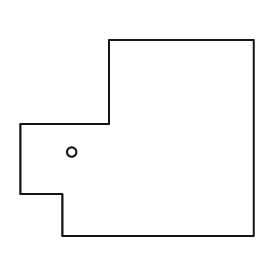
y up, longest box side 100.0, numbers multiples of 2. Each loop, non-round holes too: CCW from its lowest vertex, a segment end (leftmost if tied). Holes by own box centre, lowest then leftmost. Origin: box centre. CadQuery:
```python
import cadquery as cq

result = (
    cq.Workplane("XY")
    .moveTo(-32.0, -42.0)
    .lineTo(50.0, -42.0)
    .lineTo(50.0, 42.0)
    .lineTo(-12.0, 42.0)
    .lineTo(-12.0, 6.0)
    .lineTo(-50.0, 6.0)
    .lineTo(-50.0, -24.0)
    .lineTo(-32.0, -24.0)
    .close()
    .moveTo(-28.0, -6.0)
    .circle(2.0)
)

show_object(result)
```